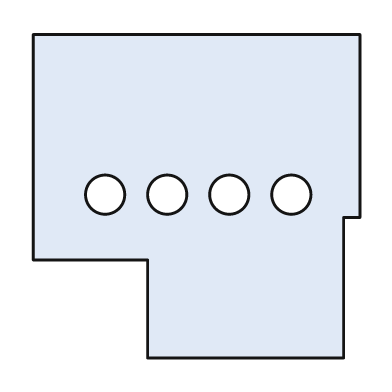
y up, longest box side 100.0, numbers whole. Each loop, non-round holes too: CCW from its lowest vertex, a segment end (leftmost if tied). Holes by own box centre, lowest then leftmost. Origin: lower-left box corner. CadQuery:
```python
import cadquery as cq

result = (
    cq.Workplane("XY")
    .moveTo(35.0, 0.0)
    .lineTo(95.0, 0.0)
    .lineTo(95.0, 43.0)
    .lineTo(100.0, 43.0)
    .lineTo(100.0, 99.0)
    .lineTo(0.0, 99.0)
    .lineTo(0.0, 30.0)
    .lineTo(35.0, 30.0)
    .close()
    .moveTo(22.0, 50.0)
    .circle(6.0)
    .moveTo(41.0, 50.0)
    .circle(6.0)
    .moveTo(60.0, 50.0)
    .circle(6.0)
    .moveTo(79.0, 50.0)
    .circle(6.0)
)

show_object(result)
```